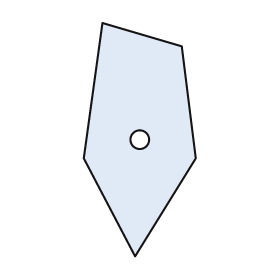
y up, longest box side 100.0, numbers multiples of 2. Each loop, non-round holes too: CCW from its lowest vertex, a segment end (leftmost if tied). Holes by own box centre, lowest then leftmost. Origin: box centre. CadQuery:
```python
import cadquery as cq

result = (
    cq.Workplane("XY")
    .moveTo(-2.0, -50.0)
    .lineTo(24.0, -8.0)
    .lineTo(18.0, 40.0)
    .lineTo(-16.0, 50.0)
    .lineTo(-24.0, -8.0)
    .close()
    .moveTo(0.0, 0.0)
    .circle(4.0)
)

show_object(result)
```